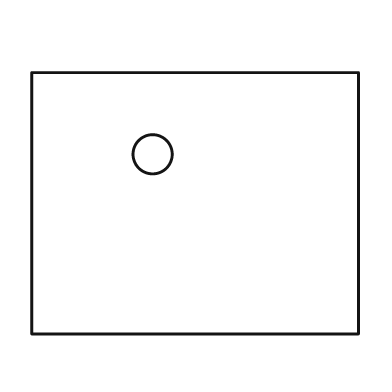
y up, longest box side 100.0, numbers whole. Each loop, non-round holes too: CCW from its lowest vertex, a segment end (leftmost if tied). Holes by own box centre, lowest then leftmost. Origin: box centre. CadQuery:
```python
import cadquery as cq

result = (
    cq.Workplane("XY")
    .moveTo(-50.0, -40.0)
    .lineTo(50.0, -40.0)
    .lineTo(50.0, 40.0)
    .lineTo(-50.0, 40.0)
    .close()
    .moveTo(-13.0, 15.0)
    .circle(6.0)
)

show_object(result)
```